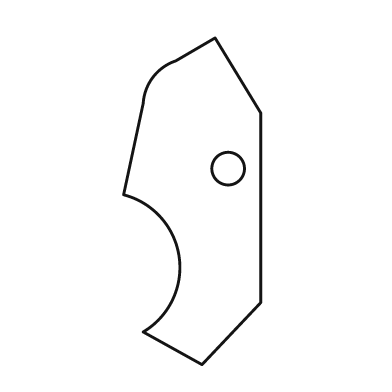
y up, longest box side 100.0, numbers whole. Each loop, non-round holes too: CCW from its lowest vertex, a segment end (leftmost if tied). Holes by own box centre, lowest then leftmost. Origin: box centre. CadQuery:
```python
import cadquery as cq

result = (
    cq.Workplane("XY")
    .moveTo(3.0, -50.0)
    .lineTo(21.0, -31.0)
    .lineTo(21.0, 27.0)
    .lineTo(7.0, 50.0)
    .lineTo(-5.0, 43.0)
    .threePointArc((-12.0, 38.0), (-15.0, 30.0))
    .lineTo(-21.0, 2.0)
    .threePointArc((-4.0, -17.0), (-15.0, -40.0))
    .close()
    .moveTo(11.0, 10.0)
    .circle(5.0)
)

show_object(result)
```